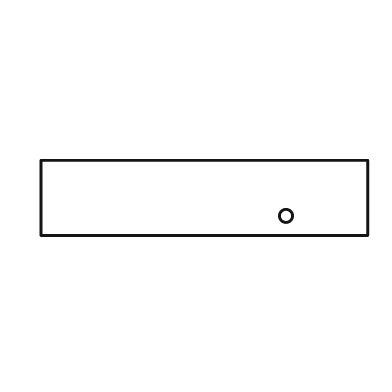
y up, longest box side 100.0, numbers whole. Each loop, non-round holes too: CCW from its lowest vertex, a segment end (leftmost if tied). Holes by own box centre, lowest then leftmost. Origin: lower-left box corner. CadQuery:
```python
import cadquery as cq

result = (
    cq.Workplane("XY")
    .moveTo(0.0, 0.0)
    .lineTo(100.0, 0.0)
    .lineTo(100.0, 23.0)
    .lineTo(0.0, 23.0)
    .close()
    .moveTo(75.0, 6.0)
    .circle(2.0)
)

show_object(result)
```